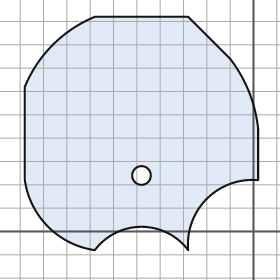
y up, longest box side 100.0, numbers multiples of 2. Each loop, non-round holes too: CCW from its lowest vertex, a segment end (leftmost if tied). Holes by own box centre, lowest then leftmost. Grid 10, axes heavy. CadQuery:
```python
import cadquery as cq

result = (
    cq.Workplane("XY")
    .moveTo(-68.0, -8.0)
    .threePointArc((-48.0, 2.0), (-28.0, -8.0))
    .threePointArc((-20.0, 14.0), (2.0, 22.0))
    .lineTo(2.0, 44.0)
    .threePointArc((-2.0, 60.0), (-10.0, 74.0))
    .lineTo(-28.0, 92.0)
    .lineTo(-68.0, 92.0)
    .threePointArc((-86.0, 80.0), (-98.0, 62.0))
    .lineTo(-98.0, 22.0)
    .threePointArc((-88.0, 2.0), (-68.0, -8.0))
    .close()
    .moveTo(-48.0, 24.0)
    .circle(4.0)
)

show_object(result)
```